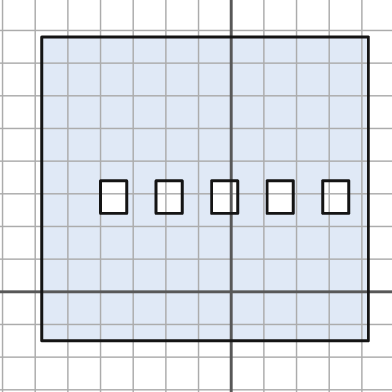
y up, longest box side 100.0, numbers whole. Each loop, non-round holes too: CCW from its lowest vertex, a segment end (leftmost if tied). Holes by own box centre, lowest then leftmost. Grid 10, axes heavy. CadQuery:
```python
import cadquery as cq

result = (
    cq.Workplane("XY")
    .moveTo(-58.0, -15.0)
    .lineTo(42.0, -15.0)
    .lineTo(42.0, 78.0)
    .lineTo(-58.0, 78.0)
    .close()
    .moveTo(-40.0, 24.0)
    .lineTo(-32.0, 24.0)
    .lineTo(-32.0, 34.0)
    .lineTo(-40.0, 34.0)
    .close()
    .moveTo(-23.0, 24.0)
    .lineTo(-15.0, 24.0)
    .lineTo(-15.0, 34.0)
    .lineTo(-23.0, 34.0)
    .close()
    .moveTo(-6.0, 24.0)
    .lineTo(2.0, 24.0)
    .lineTo(2.0, 34.0)
    .lineTo(-6.0, 34.0)
    .close()
    .moveTo(11.0, 24.0)
    .lineTo(19.0, 24.0)
    .lineTo(19.0, 34.0)
    .lineTo(11.0, 34.0)
    .close()
    .moveTo(28.0, 24.0)
    .lineTo(36.0, 24.0)
    .lineTo(36.0, 34.0)
    .lineTo(28.0, 34.0)
    .close()
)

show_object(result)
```